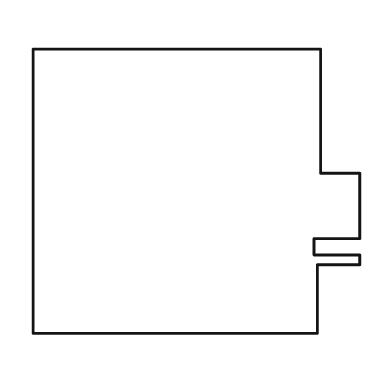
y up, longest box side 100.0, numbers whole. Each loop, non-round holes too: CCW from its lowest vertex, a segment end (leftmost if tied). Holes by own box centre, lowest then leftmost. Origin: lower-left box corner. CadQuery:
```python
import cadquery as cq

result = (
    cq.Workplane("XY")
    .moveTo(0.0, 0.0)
    .lineTo(87.0, 0.0)
    .lineTo(87.0, 21.0)
    .lineTo(100.0, 21.0)
    .lineTo(100.0, 24.0)
    .lineTo(86.0, 24.0)
    .lineTo(86.0, 29.0)
    .lineTo(100.0, 29.0)
    .lineTo(100.0, 49.0)
    .lineTo(88.0, 49.0)
    .lineTo(88.0, 87.0)
    .lineTo(0.0, 87.0)
    .close()
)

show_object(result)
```